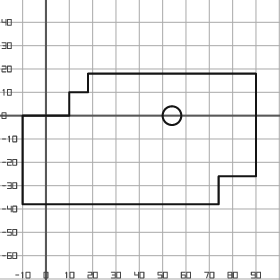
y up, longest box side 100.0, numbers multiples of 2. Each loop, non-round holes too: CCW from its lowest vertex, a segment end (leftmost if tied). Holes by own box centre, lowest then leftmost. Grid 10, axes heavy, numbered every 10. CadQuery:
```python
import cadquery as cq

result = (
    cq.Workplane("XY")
    .moveTo(-10.0, -38.0)
    .lineTo(74.0, -38.0)
    .lineTo(74.0, -26.0)
    .lineTo(90.0, -26.0)
    .lineTo(90.0, 18.0)
    .lineTo(18.0, 18.0)
    .lineTo(18.0, 10.0)
    .lineTo(10.0, 10.0)
    .lineTo(10.0, 0.0)
    .lineTo(-10.0, 0.0)
    .close()
    .moveTo(54.0, 0.0)
    .circle(4.0)
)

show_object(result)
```